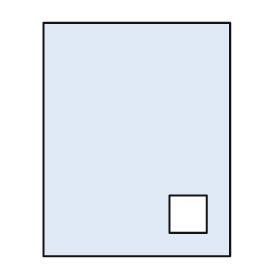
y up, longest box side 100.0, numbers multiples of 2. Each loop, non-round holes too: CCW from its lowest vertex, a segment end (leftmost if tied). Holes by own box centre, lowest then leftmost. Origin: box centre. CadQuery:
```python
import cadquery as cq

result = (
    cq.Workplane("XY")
    .moveTo(-40.0, -50.0)
    .lineTo(40.0, -50.0)
    .lineTo(40.0, 50.0)
    .lineTo(-40.0, 50.0)
    .close()
    .moveTo(14.0, -40.0)
    .lineTo(30.0, -40.0)
    .lineTo(30.0, -24.0)
    .lineTo(14.0, -24.0)
    .close()
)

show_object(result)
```